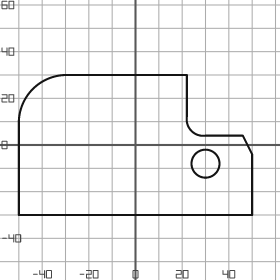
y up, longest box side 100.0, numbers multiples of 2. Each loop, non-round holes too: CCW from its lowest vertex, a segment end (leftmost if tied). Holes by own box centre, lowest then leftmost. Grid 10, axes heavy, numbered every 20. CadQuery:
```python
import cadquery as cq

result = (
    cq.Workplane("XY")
    .moveTo(-50.0, -30.0)
    .lineTo(50.0, -30.0)
    .lineTo(50.0, -4.0)
    .lineTo(46.0, 4.0)
    .lineTo(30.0, 4.0)
    .threePointArc((24.0, 6.0), (22.0, 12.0))
    .lineTo(22.0, 30.0)
    .lineTo(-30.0, 30.0)
    .threePointArc((-44.0, 24.0), (-50.0, 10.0))
    .close()
    .moveTo(30.0, -8.0)
    .circle(6.0)
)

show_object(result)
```